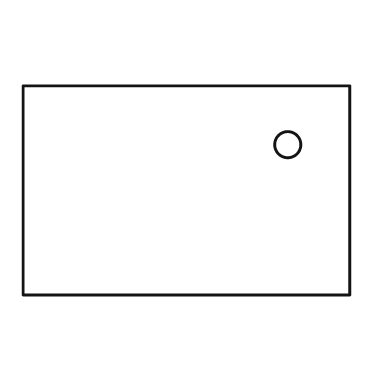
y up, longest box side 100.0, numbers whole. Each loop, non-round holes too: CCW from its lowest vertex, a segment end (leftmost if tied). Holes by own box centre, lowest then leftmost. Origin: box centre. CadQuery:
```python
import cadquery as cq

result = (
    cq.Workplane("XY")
    .moveTo(-50.0, -32.0)
    .lineTo(50.0, -32.0)
    .lineTo(50.0, 32.0)
    .lineTo(-50.0, 32.0)
    .close()
    .moveTo(31.0, 14.0)
    .circle(4.0)
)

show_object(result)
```